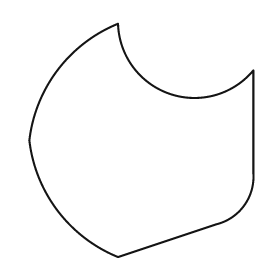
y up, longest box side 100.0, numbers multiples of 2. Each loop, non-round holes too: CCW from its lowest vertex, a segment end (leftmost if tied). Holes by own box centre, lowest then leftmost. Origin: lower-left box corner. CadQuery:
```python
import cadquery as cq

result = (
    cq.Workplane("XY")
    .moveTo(38.0, 0.0)
    .lineTo(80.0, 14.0)
    .threePointArc((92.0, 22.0), (96.0, 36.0))
    .lineTo(96.0, 80.0)
    .threePointArc((60.0, 70.0), (38.0, 100.0))
    .threePointArc((12.0, 80.0), (0.0, 50.0))
    .threePointArc((12.0, 20.0), (38.0, 0.0))
    .close()
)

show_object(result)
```